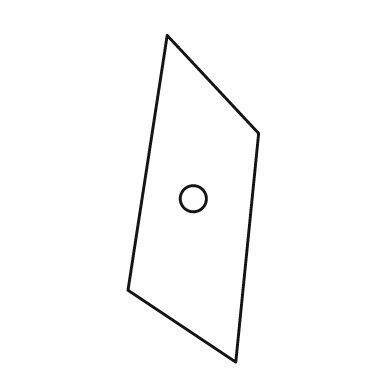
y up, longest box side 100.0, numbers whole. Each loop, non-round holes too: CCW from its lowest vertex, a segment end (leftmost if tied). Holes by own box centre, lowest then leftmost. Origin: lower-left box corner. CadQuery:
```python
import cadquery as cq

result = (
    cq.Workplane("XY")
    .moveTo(33.0, 0.0)
    .lineTo(40.0, 70.0)
    .lineTo(12.0, 100.0)
    .lineTo(0.0, 22.0)
    .close()
    .moveTo(20.0, 50.0)
    .circle(4.0)
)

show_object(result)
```